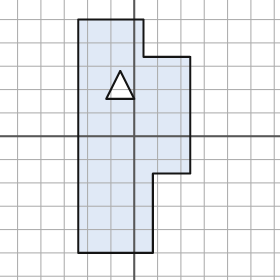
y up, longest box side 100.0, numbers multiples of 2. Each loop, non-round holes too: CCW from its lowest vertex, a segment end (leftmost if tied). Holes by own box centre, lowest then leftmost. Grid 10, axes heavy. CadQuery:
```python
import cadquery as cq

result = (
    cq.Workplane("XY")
    .moveTo(-24.0, -50.0)
    .lineTo(8.0, -50.0)
    .lineTo(8.0, -16.0)
    .lineTo(24.0, -16.0)
    .lineTo(24.0, 34.0)
    .lineTo(4.0, 34.0)
    .lineTo(4.0, 50.0)
    .lineTo(-24.0, 50.0)
    .close()
    .moveTo(-12.0, 16.0)
    .lineTo(0.0, 16.0)
    .lineTo(-6.0, 28.0)
    .close()
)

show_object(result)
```